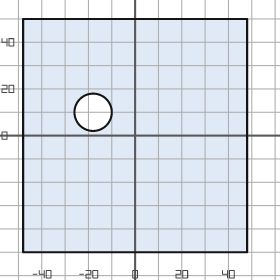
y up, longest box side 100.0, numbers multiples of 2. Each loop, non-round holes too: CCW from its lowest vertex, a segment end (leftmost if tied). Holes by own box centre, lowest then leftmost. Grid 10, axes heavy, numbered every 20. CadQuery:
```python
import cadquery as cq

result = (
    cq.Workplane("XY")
    .moveTo(-48.0, -50.0)
    .lineTo(48.0, -50.0)
    .lineTo(48.0, 50.0)
    .lineTo(-48.0, 50.0)
    .close()
    .moveTo(-18.0, 10.0)
    .circle(8.0)
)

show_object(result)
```